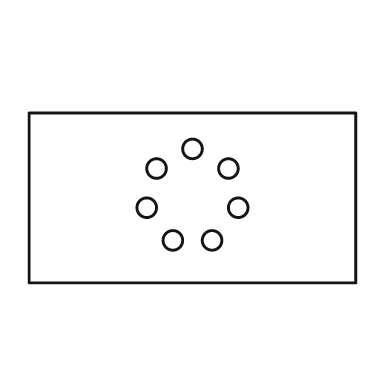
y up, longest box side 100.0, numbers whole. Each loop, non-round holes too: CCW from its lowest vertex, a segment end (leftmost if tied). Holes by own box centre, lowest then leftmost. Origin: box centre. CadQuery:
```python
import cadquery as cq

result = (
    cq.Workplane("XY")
    .moveTo(-50.0, -26.0)
    .lineTo(50.0, -26.0)
    .lineTo(50.0, 26.0)
    .lineTo(-50.0, 26.0)
    .close()
    .moveTo(-6.0, -13.0)
    .circle(3.0)
    .moveTo(6.0, -13.0)
    .circle(3.0)
    .moveTo(-14.0, -3.0)
    .circle(3.0)
    .moveTo(14.0, -3.0)
    .circle(3.0)
    .moveTo(-11.0, 9.0)
    .circle(3.0)
    .moveTo(11.0, 9.0)
    .circle(3.0)
    .moveTo(0.0, 15.0)
    .circle(3.0)
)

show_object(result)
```